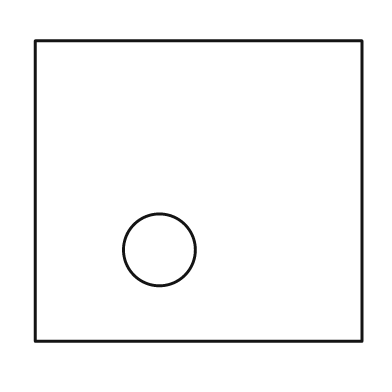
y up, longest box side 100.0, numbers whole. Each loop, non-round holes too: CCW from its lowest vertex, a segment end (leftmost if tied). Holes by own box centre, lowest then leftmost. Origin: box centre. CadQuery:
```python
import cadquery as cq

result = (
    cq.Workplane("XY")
    .moveTo(-50.0, -46.0)
    .lineTo(50.0, -46.0)
    .lineTo(50.0, 46.0)
    .lineTo(-50.0, 46.0)
    .close()
    .moveTo(-12.0, -18.0)
    .circle(11.0)
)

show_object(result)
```